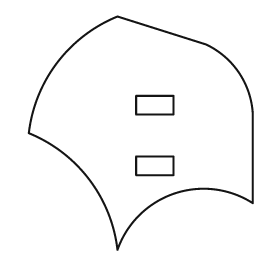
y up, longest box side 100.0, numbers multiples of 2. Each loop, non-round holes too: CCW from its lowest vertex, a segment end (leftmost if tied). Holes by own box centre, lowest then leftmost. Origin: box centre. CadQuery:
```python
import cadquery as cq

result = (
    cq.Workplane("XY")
    .moveTo(-10.0, -50.0)
    .threePointArc((14.0, -26.0), (48.0, -30.0))
    .lineTo(48.0, 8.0)
    .threePointArc((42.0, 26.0), (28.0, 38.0))
    .lineTo(-10.0, 50.0)
    .threePointArc((-36.0, 30.0), (-48.0, 0.0))
    .threePointArc((-22.0, -20.0), (-10.0, -50.0))
    .close()
    .moveTo(-2.0, -18.0)
    .lineTo(14.0, -18.0)
    .lineTo(14.0, -10.0)
    .lineTo(-2.0, -10.0)
    .close()
    .moveTo(-2.0, 8.0)
    .lineTo(14.0, 8.0)
    .lineTo(14.0, 16.0)
    .lineTo(-2.0, 16.0)
    .close()
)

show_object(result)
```